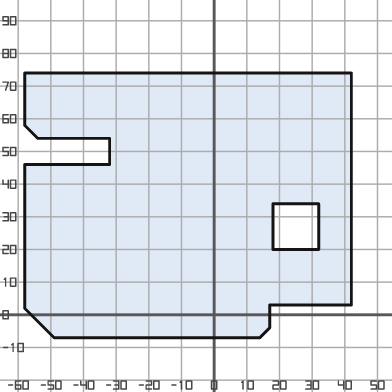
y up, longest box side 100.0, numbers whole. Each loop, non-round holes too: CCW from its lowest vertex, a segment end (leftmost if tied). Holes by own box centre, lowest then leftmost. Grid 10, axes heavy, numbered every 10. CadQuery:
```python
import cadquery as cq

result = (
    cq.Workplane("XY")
    .moveTo(-49.0, -7.0)
    .lineTo(14.0, -7.0)
    .lineTo(17.0, -4.0)
    .lineTo(17.0, 3.0)
    .lineTo(42.0, 3.0)
    .lineTo(42.0, 74.0)
    .lineTo(-58.0, 74.0)
    .lineTo(-58.0, 58.0)
    .lineTo(-54.0, 54.0)
    .lineTo(-32.0, 54.0)
    .lineTo(-32.0, 46.0)
    .lineTo(-58.0, 46.0)
    .lineTo(-58.0, 2.0)
    .close()
    .moveTo(18.0, 20.0)
    .lineTo(32.0, 20.0)
    .lineTo(32.0, 34.0)
    .lineTo(18.0, 34.0)
    .close()
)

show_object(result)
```